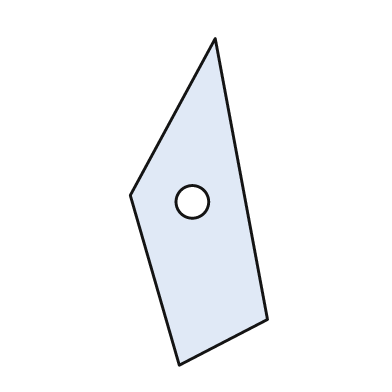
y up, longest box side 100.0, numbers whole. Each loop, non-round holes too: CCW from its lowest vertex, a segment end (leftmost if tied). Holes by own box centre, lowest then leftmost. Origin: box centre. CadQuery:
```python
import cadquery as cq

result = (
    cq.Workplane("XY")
    .moveTo(-6.0, -50.0)
    .lineTo(21.0, -36.0)
    .lineTo(5.0, 50.0)
    .lineTo(-21.0, 2.0)
    .close()
    .moveTo(-2.0, 0.0)
    .circle(5.0)
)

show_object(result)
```